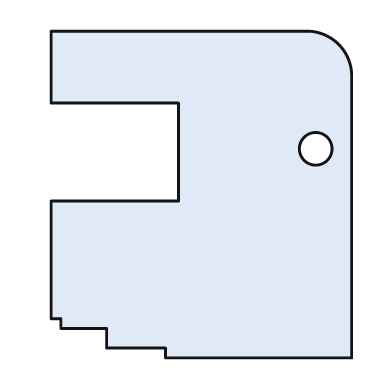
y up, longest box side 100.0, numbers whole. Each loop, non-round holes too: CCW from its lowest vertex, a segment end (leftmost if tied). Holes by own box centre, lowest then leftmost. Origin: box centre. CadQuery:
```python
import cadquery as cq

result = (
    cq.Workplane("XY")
    .moveTo(-11.0, -50.0)
    .lineTo(46.0, -50.0)
    .lineTo(46.0, 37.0)
    .threePointArc((42.0, 46.0), (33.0, 50.0))
    .lineTo(-46.0, 50.0)
    .lineTo(-46.0, 28.0)
    .lineTo(-7.0, 28.0)
    .lineTo(-7.0, -2.0)
    .lineTo(-46.0, -2.0)
    .lineTo(-46.0, -38.0)
    .lineTo(-43.0, -38.0)
    .lineTo(-43.0, -41.0)
    .lineTo(-29.0, -41.0)
    .lineTo(-29.0, -47.0)
    .lineTo(-11.0, -47.0)
    .close()
    .moveTo(35.0, 14.0)
    .circle(5.0)
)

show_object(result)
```